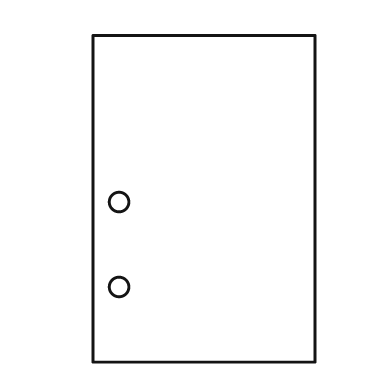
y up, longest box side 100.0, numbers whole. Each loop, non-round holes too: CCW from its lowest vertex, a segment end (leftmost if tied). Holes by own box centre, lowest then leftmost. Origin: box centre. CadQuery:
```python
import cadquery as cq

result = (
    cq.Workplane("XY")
    .moveTo(-34.0, -50.0)
    .lineTo(34.0, -50.0)
    .lineTo(34.0, 50.0)
    .lineTo(-34.0, 50.0)
    .close()
    .moveTo(-26.0, -27.0)
    .circle(3.0)
    .moveTo(-26.0, -1.0)
    .circle(3.0)
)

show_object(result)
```